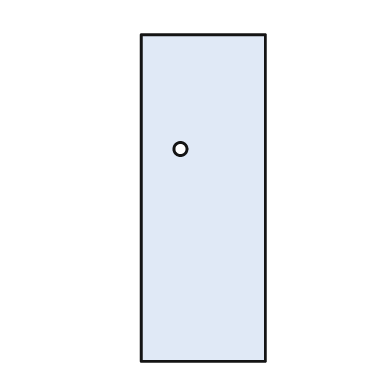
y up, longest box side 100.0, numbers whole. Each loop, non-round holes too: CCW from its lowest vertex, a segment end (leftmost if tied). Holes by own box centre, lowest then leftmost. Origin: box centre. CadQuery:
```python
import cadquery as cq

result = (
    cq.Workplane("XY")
    .moveTo(-19.0, -50.0)
    .lineTo(19.0, -50.0)
    .lineTo(19.0, 50.0)
    .lineTo(-19.0, 50.0)
    .close()
    .moveTo(-7.0, 15.0)
    .circle(2.0)
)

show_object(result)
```